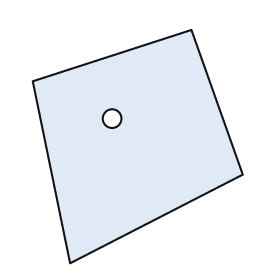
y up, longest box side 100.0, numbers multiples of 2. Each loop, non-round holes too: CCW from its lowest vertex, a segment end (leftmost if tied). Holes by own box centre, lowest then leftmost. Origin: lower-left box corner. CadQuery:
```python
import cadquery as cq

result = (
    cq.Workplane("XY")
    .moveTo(16.0, 0.0)
    .lineTo(90.0, 38.0)
    .lineTo(68.0, 100.0)
    .lineTo(0.0, 78.0)
    .close()
    .moveTo(34.0, 62.0)
    .circle(4.0)
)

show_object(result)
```